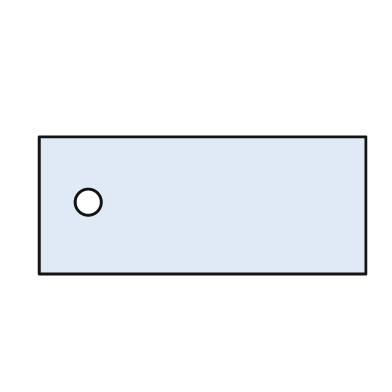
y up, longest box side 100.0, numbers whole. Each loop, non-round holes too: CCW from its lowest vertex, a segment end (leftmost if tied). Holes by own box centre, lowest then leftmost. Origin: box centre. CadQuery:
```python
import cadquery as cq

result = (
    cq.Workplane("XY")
    .moveTo(-50.0, -21.0)
    .lineTo(50.0, -21.0)
    .lineTo(50.0, 21.0)
    .lineTo(-50.0, 21.0)
    .close()
    .moveTo(-35.0, 1.0)
    .circle(4.0)
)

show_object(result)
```